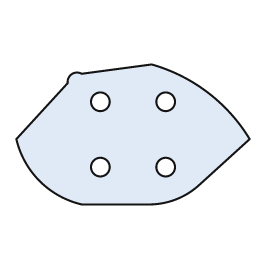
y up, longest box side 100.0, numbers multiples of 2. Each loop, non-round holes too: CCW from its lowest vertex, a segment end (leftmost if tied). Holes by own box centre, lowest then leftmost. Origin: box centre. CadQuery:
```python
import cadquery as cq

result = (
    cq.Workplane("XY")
    .moveTo(-22.0, -30.0)
    .lineTo(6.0, -30.0)
    .threePointArc((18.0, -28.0), (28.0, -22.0))
    .lineTo(50.0, -2.0)
    .threePointArc((32.0, 18.0), (8.0, 30.0))
    .lineTo(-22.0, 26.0)
    .threePointArc((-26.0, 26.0), (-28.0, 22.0))
    .lineTo(-50.0, -2.0)
    .threePointArc((-40.0, -20.0), (-22.0, -30.0))
    .close()
    .moveTo(-14.0, -14.0)
    .circle(4.0)
    .moveTo(14.0, -14.0)
    .circle(4.0)
    .moveTo(-14.0, 14.0)
    .circle(4.0)
    .moveTo(14.0, 14.0)
    .circle(4.0)
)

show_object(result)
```